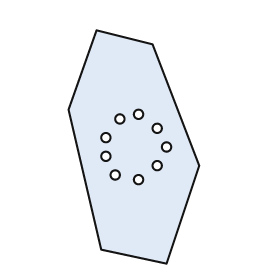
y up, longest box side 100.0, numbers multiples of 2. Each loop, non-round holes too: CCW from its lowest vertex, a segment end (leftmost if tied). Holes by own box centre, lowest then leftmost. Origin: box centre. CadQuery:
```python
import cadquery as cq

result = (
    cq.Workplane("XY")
    .moveTo(14.0, -50.0)
    .lineTo(28.0, -8.0)
    .lineTo(8.0, 44.0)
    .lineTo(-16.0, 50.0)
    .lineTo(-28.0, 16.0)
    .lineTo(-14.0, -44.0)
    .close()
    .moveTo(2.0, -14.0)
    .circle(2.0)
    .moveTo(-8.0, -12.0)
    .circle(2.0)
    .moveTo(10.0, -8.0)
    .circle(2.0)
    .moveTo(-12.0, -4.0)
    .circle(2.0)
    .moveTo(14.0, 0.0)
    .circle(2.0)
    .moveTo(-12.0, 4.0)
    .circle(2.0)
    .moveTo(10.0, 8.0)
    .circle(2.0)
    .moveTo(-6.0, 12.0)
    .circle(2.0)
    .moveTo(2.0, 14.0)
    .circle(2.0)
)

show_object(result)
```